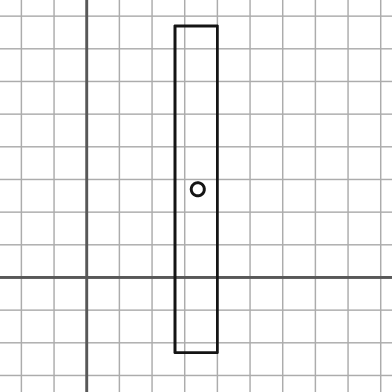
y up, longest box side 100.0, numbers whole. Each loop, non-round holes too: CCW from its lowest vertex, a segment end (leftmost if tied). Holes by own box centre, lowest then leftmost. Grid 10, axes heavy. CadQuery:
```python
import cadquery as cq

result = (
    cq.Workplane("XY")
    .moveTo(27.0, -23.0)
    .lineTo(40.0, -23.0)
    .lineTo(40.0, 77.0)
    .lineTo(27.0, 77.0)
    .close()
    .moveTo(34.0, 27.0)
    .circle(2.0)
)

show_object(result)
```